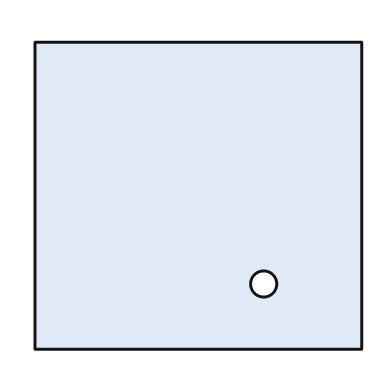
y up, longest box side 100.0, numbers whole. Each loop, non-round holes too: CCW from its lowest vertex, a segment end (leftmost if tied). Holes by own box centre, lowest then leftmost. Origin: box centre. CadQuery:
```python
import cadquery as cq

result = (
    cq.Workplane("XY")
    .moveTo(-50.0, -47.0)
    .lineTo(50.0, -47.0)
    .lineTo(50.0, 47.0)
    .lineTo(-50.0, 47.0)
    .close()
    .moveTo(20.0, -27.0)
    .circle(4.0)
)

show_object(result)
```